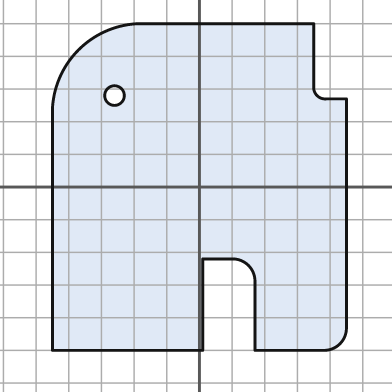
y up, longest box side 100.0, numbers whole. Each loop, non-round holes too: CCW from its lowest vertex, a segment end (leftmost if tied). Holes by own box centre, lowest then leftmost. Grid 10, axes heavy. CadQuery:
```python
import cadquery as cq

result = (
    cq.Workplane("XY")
    .moveTo(-45.0, -50.0)
    .lineTo(1.0, -50.0)
    .lineTo(1.0, -22.0)
    .lineTo(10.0, -22.0)
    .threePointArc((15.0, -24.0), (17.0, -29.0))
    .lineTo(17.0, -50.0)
    .lineTo(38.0, -50.0)
    .threePointArc((43.0, -48.0), (45.0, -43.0))
    .lineTo(45.0, 27.0)
    .lineTo(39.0, 27.0)
    .threePointArc((36.0, 28.0), (35.0, 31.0))
    .lineTo(35.0, 50.0)
    .lineTo(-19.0, 50.0)
    .threePointArc((-37.0, 42.0), (-45.0, 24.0))
    .close()
    .moveTo(-26.0, 28.0)
    .circle(3.0)
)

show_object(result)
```